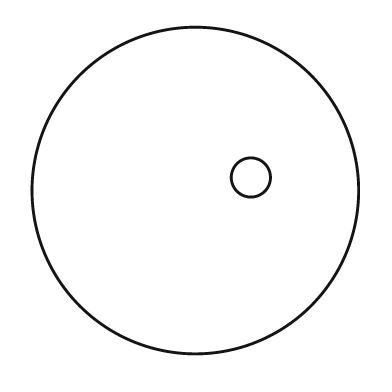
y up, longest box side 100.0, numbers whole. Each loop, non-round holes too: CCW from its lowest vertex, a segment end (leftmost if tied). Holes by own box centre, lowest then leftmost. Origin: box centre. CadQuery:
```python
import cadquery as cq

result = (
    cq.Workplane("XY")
    .moveTo(0.0, 0.0)
    .circle(50.0)
    .moveTo(17.0, 4.0)
    .circle(6.0)
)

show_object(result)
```